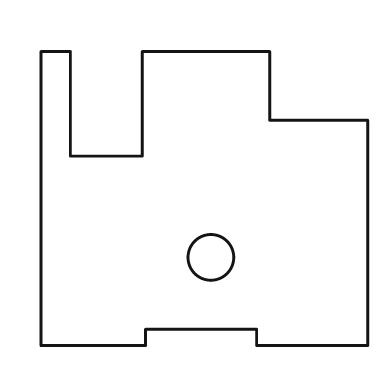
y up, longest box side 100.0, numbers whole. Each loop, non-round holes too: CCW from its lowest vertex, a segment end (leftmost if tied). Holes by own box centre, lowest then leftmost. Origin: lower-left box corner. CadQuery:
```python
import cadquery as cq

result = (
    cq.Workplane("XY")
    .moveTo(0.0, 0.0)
    .lineTo(32.0, 0.0)
    .lineTo(32.0, 5.0)
    .lineTo(66.0, 5.0)
    .lineTo(66.0, 0.0)
    .lineTo(100.0, 0.0)
    .lineTo(100.0, 69.0)
    .lineTo(70.0, 69.0)
    .lineTo(70.0, 90.0)
    .lineTo(31.0, 90.0)
    .lineTo(31.0, 58.0)
    .lineTo(9.0, 58.0)
    .lineTo(9.0, 90.0)
    .lineTo(0.0, 90.0)
    .close()
    .moveTo(52.0, 27.0)
    .circle(7.0)
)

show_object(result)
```